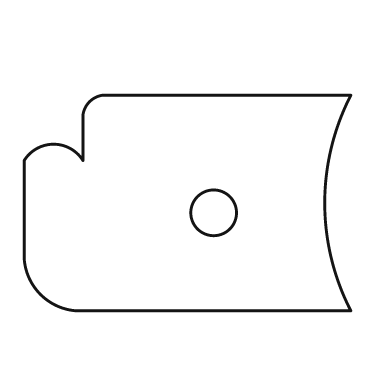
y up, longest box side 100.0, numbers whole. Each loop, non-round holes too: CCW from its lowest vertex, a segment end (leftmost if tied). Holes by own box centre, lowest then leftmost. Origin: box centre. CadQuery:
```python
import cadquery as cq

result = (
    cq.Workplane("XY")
    .moveTo(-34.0, -33.0)
    .lineTo(50.0, -33.0)
    .threePointArc((42.0, 0.0), (50.0, 33.0))
    .lineTo(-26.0, 33.0)
    .threePointArc((-30.0, 31.0), (-32.0, 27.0))
    .lineTo(-32.0, 13.0)
    .threePointArc((-41.0, 18.0), (-50.0, 13.0))
    .lineTo(-50.0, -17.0)
    .threePointArc((-45.0, -28.0), (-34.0, -33.0))
    .close()
    .moveTo(8.0, -3.0)
    .circle(7.0)
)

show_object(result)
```